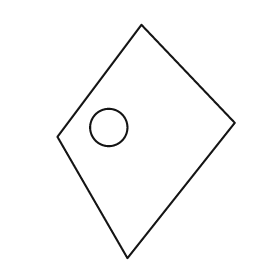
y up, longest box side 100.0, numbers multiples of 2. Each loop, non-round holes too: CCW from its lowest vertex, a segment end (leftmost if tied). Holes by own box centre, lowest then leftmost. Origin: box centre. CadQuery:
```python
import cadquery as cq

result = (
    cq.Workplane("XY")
    .moveTo(-8.0, -50.0)
    .lineTo(38.0, 8.0)
    .lineTo(-2.0, 50.0)
    .lineTo(-38.0, 2.0)
    .close()
    .moveTo(-16.0, 6.0)
    .circle(8.0)
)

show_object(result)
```